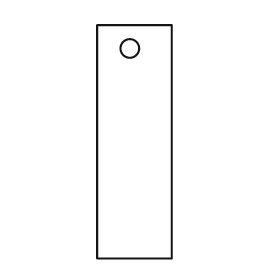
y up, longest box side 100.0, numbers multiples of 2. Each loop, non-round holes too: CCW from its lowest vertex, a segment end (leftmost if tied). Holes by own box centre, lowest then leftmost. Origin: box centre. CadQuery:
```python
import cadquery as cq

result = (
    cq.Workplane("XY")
    .moveTo(-16.0, -50.0)
    .lineTo(16.0, -50.0)
    .lineTo(16.0, 50.0)
    .lineTo(-16.0, 50.0)
    .close()
    .moveTo(-2.0, 40.0)
    .circle(4.0)
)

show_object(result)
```